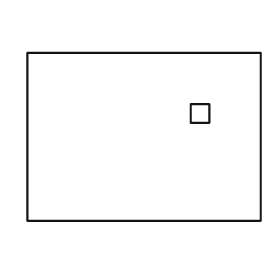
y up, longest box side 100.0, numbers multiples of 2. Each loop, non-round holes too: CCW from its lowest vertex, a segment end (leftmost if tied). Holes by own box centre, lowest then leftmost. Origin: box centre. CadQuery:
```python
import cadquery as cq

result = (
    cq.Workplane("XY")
    .moveTo(-50.0, -36.0)
    .lineTo(50.0, -36.0)
    .lineTo(50.0, 36.0)
    .lineTo(-50.0, 36.0)
    .close()
    .moveTo(20.0, 6.0)
    .lineTo(28.0, 6.0)
    .lineTo(28.0, 14.0)
    .lineTo(20.0, 14.0)
    .close()
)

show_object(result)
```